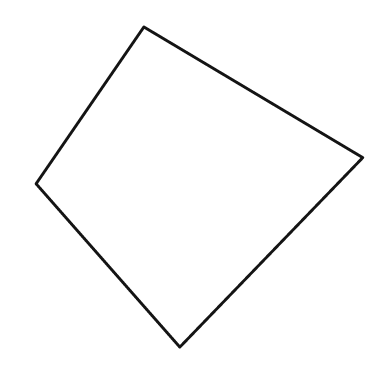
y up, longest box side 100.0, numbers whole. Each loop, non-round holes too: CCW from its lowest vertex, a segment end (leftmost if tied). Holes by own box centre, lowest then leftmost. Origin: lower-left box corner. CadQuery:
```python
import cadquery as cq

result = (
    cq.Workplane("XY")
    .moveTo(44.0, 0.0)
    .lineTo(100.0, 58.0)
    .lineTo(33.0, 98.0)
    .lineTo(0.0, 50.0)
    .close()
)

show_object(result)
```